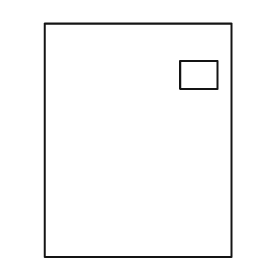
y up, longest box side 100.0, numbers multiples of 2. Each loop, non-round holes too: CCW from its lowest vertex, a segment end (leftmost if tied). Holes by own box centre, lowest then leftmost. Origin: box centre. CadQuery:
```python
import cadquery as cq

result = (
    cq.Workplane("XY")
    .moveTo(-40.0, -50.0)
    .lineTo(40.0, -50.0)
    .lineTo(40.0, 50.0)
    .lineTo(-40.0, 50.0)
    .close()
    .moveTo(18.0, 22.0)
    .lineTo(34.0, 22.0)
    .lineTo(34.0, 34.0)
    .lineTo(18.0, 34.0)
    .close()
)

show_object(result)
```